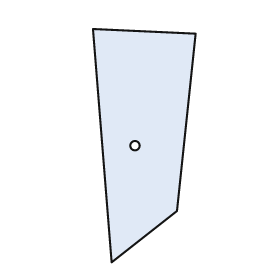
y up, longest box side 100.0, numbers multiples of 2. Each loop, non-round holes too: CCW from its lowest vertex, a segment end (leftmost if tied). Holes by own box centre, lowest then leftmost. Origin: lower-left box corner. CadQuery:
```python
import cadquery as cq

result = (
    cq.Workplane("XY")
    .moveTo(8.0, 0.0)
    .lineTo(36.0, 22.0)
    .lineTo(44.0, 98.0)
    .lineTo(0.0, 100.0)
    .close()
    .moveTo(18.0, 50.0)
    .circle(2.0)
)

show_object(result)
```